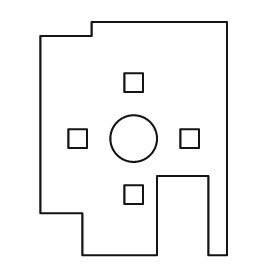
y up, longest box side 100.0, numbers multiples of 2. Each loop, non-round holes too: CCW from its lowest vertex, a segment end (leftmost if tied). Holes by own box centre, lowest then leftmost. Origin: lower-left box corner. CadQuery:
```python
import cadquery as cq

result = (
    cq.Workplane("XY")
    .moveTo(18.0, 0.0)
    .lineTo(50.0, 0.0)
    .lineTo(50.0, 34.0)
    .lineTo(72.0, 34.0)
    .lineTo(72.0, 0.0)
    .lineTo(80.0, 0.0)
    .lineTo(80.0, 100.0)
    .lineTo(22.0, 100.0)
    .lineTo(22.0, 94.0)
    .lineTo(0.0, 94.0)
    .lineTo(0.0, 18.0)
    .lineTo(18.0, 18.0)
    .close()
    .moveTo(36.0, 22.0)
    .lineTo(44.0, 22.0)
    .lineTo(44.0, 30.0)
    .lineTo(36.0, 30.0)
    .close()
    .moveTo(12.0, 46.0)
    .lineTo(20.0, 46.0)
    .lineTo(20.0, 54.0)
    .lineTo(12.0, 54.0)
    .close()
    .moveTo(40.0, 50.0)
    .circle(10.0)
    .moveTo(60.0, 46.0)
    .lineTo(68.0, 46.0)
    .lineTo(68.0, 54.0)
    .lineTo(60.0, 54.0)
    .close()
    .moveTo(36.0, 70.0)
    .lineTo(44.0, 70.0)
    .lineTo(44.0, 78.0)
    .lineTo(36.0, 78.0)
    .close()
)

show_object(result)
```